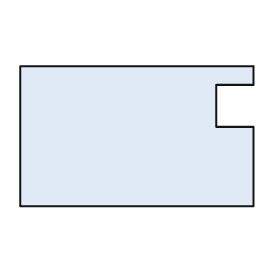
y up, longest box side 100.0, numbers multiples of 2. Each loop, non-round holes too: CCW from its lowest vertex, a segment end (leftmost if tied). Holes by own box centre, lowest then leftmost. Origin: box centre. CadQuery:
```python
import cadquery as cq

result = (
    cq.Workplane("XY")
    .moveTo(-50.0, -30.0)
    .lineTo(50.0, -30.0)
    .lineTo(50.0, 4.0)
    .lineTo(34.0, 4.0)
    .lineTo(34.0, 22.0)
    .lineTo(50.0, 22.0)
    .lineTo(50.0, 30.0)
    .lineTo(-50.0, 30.0)
    .close()
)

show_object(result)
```